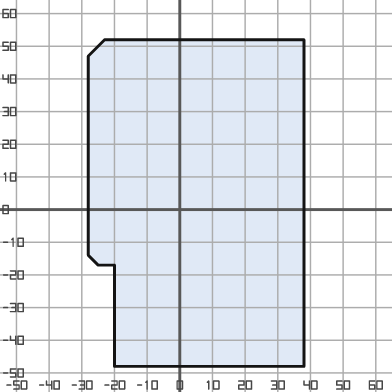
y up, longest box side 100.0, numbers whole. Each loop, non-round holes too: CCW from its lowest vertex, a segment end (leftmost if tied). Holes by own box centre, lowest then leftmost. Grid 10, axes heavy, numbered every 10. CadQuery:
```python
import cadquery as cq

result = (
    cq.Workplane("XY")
    .moveTo(-20.0, -48.0)
    .lineTo(38.0, -48.0)
    .lineTo(38.0, 52.0)
    .lineTo(-23.0, 52.0)
    .lineTo(-28.0, 47.0)
    .lineTo(-28.0, -14.0)
    .lineTo(-25.0, -17.0)
    .lineTo(-20.0, -17.0)
    .close()
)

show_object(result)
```